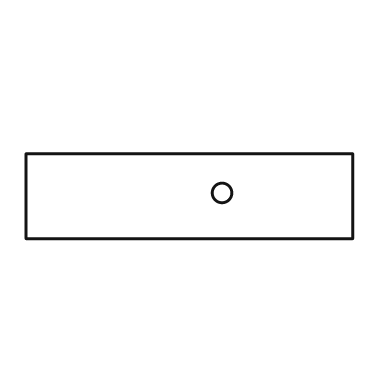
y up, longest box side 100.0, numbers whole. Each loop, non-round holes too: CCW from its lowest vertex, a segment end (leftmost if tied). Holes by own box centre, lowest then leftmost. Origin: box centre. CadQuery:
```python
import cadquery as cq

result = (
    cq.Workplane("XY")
    .moveTo(-50.0, -13.0)
    .lineTo(50.0, -13.0)
    .lineTo(50.0, 13.0)
    .lineTo(-50.0, 13.0)
    .close()
    .moveTo(10.0, 1.0)
    .circle(3.0)
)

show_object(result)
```